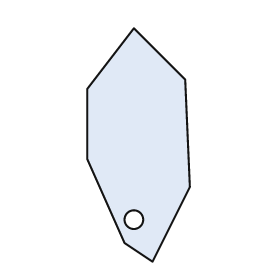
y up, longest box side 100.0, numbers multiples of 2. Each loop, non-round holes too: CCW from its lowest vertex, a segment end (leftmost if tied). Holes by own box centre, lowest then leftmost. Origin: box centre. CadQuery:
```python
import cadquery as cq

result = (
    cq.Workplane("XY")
    .moveTo(6.0, -50.0)
    .lineTo(22.0, -18.0)
    .lineTo(20.0, 28.0)
    .lineTo(-2.0, 50.0)
    .lineTo(-22.0, 24.0)
    .lineTo(-22.0, -6.0)
    .lineTo(-6.0, -42.0)
    .close()
    .moveTo(-2.0, -32.0)
    .circle(4.0)
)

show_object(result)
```